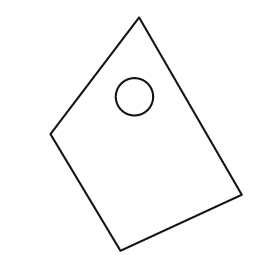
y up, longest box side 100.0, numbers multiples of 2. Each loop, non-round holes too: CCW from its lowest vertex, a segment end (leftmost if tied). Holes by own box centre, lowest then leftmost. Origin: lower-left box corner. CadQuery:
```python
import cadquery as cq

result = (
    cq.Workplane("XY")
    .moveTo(30.0, 0.0)
    .lineTo(82.0, 24.0)
    .lineTo(38.0, 100.0)
    .lineTo(0.0, 50.0)
    .close()
    .moveTo(36.0, 66.0)
    .circle(8.0)
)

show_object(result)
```